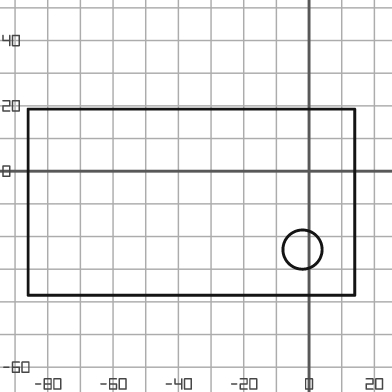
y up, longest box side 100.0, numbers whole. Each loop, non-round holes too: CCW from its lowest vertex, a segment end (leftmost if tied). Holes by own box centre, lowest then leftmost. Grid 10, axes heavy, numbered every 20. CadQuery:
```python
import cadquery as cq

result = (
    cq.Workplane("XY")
    .moveTo(-86.0, -38.0)
    .lineTo(14.0, -38.0)
    .lineTo(14.0, 19.0)
    .lineTo(-86.0, 19.0)
    .close()
    .moveTo(-2.0, -24.0)
    .circle(6.0)
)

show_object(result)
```